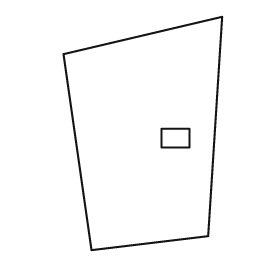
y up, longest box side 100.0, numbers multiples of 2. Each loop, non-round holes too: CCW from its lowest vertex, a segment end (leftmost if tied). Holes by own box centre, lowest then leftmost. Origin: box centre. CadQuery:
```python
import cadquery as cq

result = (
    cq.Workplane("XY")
    .moveTo(-22.0, -50.0)
    .lineTo(28.0, -44.0)
    .lineTo(34.0, 50.0)
    .lineTo(-34.0, 34.0)
    .close()
    .moveTo(8.0, -6.0)
    .lineTo(20.0, -6.0)
    .lineTo(20.0, 2.0)
    .lineTo(8.0, 2.0)
    .close()
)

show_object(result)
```